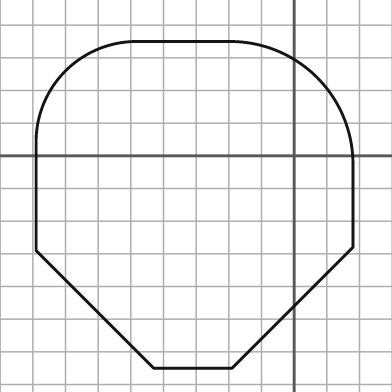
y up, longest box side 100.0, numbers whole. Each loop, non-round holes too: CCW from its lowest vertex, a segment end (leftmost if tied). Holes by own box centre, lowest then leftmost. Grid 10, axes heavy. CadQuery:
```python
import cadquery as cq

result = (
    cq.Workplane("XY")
    .moveTo(-43.0, -65.0)
    .lineTo(-19.0, -65.0)
    .lineTo(18.0, -28.0)
    .lineTo(18.0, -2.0)
    .threePointArc((7.0, 24.0), (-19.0, 35.0))
    .lineTo(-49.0, 35.0)
    .threePointArc((-70.0, 26.0), (-79.0, 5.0))
    .lineTo(-79.0, -29.0)
    .close()
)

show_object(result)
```